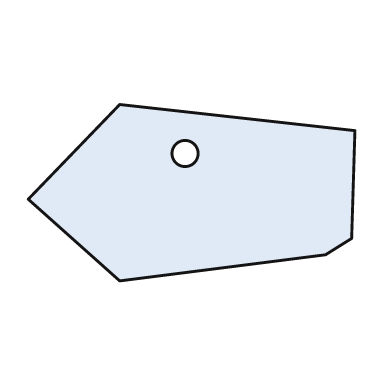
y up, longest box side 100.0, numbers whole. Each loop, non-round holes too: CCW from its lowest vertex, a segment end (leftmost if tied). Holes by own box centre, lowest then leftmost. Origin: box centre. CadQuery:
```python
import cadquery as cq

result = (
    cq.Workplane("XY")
    .moveTo(-22.0, -27.0)
    .lineTo(41.0, -19.0)
    .lineTo(49.0, -14.0)
    .lineTo(50.0, 19.0)
    .lineTo(-22.0, 27.0)
    .lineTo(-50.0, -2.0)
    .close()
    .moveTo(-2.0, 12.0)
    .circle(4.0)
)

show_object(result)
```